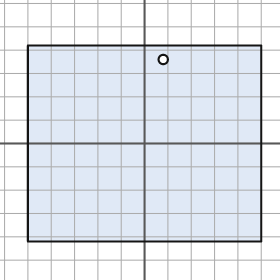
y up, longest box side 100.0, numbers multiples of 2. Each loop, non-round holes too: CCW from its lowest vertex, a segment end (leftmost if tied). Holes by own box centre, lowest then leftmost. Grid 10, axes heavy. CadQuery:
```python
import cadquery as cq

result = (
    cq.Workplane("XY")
    .moveTo(-50.0, -42.0)
    .lineTo(50.0, -42.0)
    .lineTo(50.0, 42.0)
    .lineTo(-50.0, 42.0)
    .close()
    .moveTo(8.0, 36.0)
    .circle(2.0)
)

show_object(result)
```